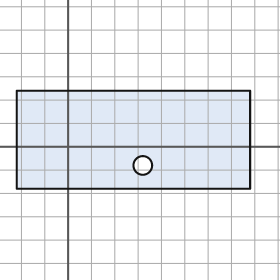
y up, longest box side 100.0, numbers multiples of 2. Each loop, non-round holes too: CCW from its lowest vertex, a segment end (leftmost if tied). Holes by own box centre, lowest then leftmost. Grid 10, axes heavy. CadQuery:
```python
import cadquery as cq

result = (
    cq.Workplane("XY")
    .moveTo(-22.0, -18.0)
    .lineTo(78.0, -18.0)
    .lineTo(78.0, 24.0)
    .lineTo(-22.0, 24.0)
    .close()
    .moveTo(32.0, -8.0)
    .circle(4.0)
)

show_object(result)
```